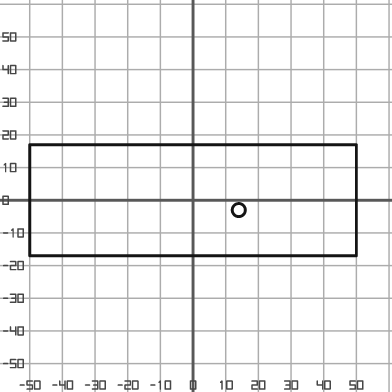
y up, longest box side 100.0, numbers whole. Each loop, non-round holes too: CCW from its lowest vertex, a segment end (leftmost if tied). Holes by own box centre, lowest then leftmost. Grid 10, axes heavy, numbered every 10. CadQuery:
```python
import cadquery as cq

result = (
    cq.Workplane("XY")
    .moveTo(-50.0, -17.0)
    .lineTo(50.0, -17.0)
    .lineTo(50.0, 17.0)
    .lineTo(-50.0, 17.0)
    .close()
    .moveTo(14.0, -3.0)
    .circle(2.0)
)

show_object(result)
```